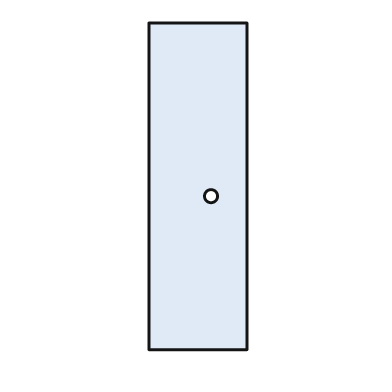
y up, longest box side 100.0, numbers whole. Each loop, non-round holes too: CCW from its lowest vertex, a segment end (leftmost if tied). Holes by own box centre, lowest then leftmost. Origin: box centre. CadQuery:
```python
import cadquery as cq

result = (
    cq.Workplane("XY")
    .moveTo(-15.0, -50.0)
    .lineTo(15.0, -50.0)
    .lineTo(15.0, 50.0)
    .lineTo(-15.0, 50.0)
    .close()
    .moveTo(4.0, -3.0)
    .circle(2.0)
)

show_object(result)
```